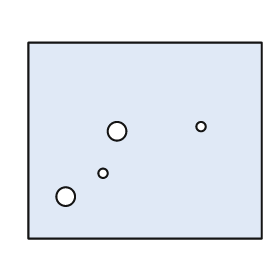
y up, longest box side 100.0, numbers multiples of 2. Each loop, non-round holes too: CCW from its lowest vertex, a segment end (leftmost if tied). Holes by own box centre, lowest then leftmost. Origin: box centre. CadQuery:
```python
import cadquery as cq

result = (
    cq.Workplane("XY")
    .moveTo(-50.0, -42.0)
    .lineTo(50.0, -42.0)
    .lineTo(50.0, 42.0)
    .lineTo(-50.0, 42.0)
    .close()
    .moveTo(-34.0, -24.0)
    .circle(4.0)
    .moveTo(-18.0, -14.0)
    .circle(2.0)
    .moveTo(-12.0, 4.0)
    .circle(4.0)
    .moveTo(24.0, 6.0)
    .circle(2.0)
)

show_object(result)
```